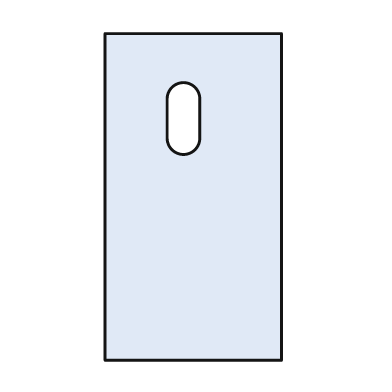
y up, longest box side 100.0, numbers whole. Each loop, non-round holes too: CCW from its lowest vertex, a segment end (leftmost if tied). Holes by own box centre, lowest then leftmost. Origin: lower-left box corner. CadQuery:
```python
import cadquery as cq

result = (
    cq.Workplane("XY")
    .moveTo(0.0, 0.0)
    .lineTo(54.0, 0.0)
    .lineTo(54.0, 100.0)
    .lineTo(0.0, 100.0)
    .close()
    .moveTo(19.0, 68.0)
    .threePointArc((24.0, 63.0), (29.0, 68.0))
    .lineTo(29.0, 80.0)
    .threePointArc((24.0, 85.0), (19.0, 80.0))
    .close()
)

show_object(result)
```